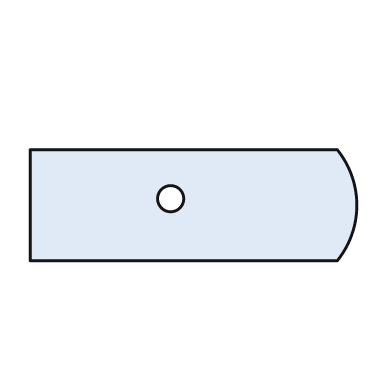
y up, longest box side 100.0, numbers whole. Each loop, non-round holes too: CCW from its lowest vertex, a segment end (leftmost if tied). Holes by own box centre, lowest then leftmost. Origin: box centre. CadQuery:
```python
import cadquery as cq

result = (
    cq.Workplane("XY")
    .moveTo(-50.0, -17.0)
    .lineTo(44.0, -17.0)
    .threePointArc((50.0, 0.0), (44.0, 17.0))
    .lineTo(-50.0, 17.0)
    .close()
    .moveTo(-7.0, 2.0)
    .circle(4.0)
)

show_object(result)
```